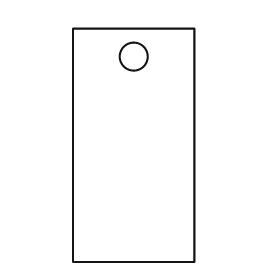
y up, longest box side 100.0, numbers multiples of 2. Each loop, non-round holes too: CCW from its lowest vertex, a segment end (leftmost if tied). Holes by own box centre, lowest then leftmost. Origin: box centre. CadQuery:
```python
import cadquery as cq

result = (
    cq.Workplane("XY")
    .moveTo(-26.0, -50.0)
    .lineTo(26.0, -50.0)
    .lineTo(26.0, 50.0)
    .lineTo(-26.0, 50.0)
    .close()
    .moveTo(0.0, 38.0)
    .circle(6.0)
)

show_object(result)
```